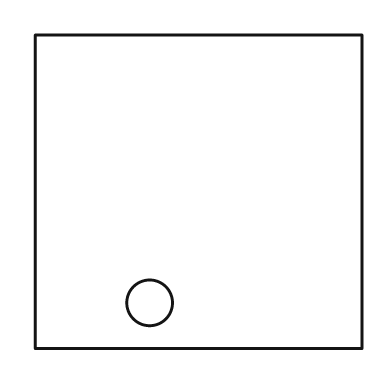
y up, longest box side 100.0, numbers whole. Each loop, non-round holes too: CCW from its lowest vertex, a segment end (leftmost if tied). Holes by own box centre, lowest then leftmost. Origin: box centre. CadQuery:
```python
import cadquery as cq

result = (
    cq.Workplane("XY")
    .moveTo(-50.0, -48.0)
    .lineTo(50.0, -48.0)
    .lineTo(50.0, 48.0)
    .lineTo(-50.0, 48.0)
    .close()
    .moveTo(-15.0, -34.0)
    .circle(7.0)
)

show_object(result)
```